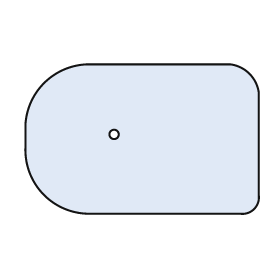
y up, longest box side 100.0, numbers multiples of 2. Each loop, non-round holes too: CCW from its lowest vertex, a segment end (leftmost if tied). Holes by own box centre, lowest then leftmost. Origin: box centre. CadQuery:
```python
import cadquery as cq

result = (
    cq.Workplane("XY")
    .moveTo(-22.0, -32.0)
    .lineTo(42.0, -32.0)
    .threePointArc((48.0, -30.0), (50.0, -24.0))
    .lineTo(50.0, 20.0)
    .threePointArc((46.0, 28.0), (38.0, 32.0))
    .lineTo(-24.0, 32.0)
    .threePointArc((-42.0, 24.0), (-50.0, 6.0))
    .lineTo(-50.0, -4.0)
    .threePointArc((-42.0, -24.0), (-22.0, -32.0))
    .close()
    .moveTo(-12.0, 2.0)
    .circle(2.0)
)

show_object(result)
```